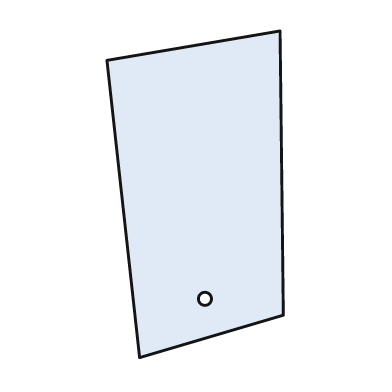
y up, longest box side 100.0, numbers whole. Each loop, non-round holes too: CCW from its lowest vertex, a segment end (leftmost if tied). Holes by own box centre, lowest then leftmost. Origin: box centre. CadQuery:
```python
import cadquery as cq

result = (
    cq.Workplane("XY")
    .moveTo(-17.0, -50.0)
    .lineTo(27.0, -37.0)
    .lineTo(26.0, 50.0)
    .lineTo(-27.0, 41.0)
    .close()
    .moveTo(3.0, -32.0)
    .circle(2.0)
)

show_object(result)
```